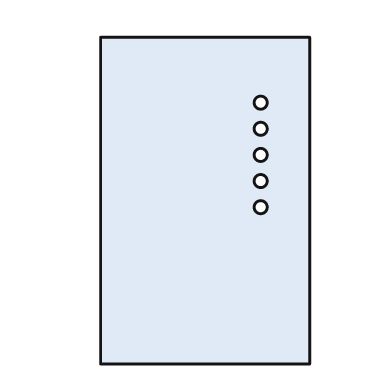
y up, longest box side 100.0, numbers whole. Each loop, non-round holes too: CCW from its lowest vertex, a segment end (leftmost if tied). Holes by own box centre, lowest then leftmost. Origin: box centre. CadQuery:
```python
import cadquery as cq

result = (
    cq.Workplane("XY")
    .moveTo(-32.0, -50.0)
    .lineTo(32.0, -50.0)
    .lineTo(32.0, 50.0)
    .lineTo(-32.0, 50.0)
    .close()
    .moveTo(17.0, -2.0)
    .circle(2.0)
    .moveTo(17.0, 6.0)
    .circle(2.0)
    .moveTo(17.0, 14.0)
    .circle(2.0)
    .moveTo(17.0, 22.0)
    .circle(2.0)
    .moveTo(17.0, 30.0)
    .circle(2.0)
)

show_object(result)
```